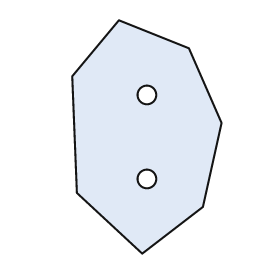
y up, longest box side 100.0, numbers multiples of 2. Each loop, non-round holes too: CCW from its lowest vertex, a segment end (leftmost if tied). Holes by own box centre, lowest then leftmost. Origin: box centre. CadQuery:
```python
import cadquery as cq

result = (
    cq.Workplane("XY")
    .moveTo(-2.0, -50.0)
    .lineTo(24.0, -30.0)
    .lineTo(32.0, 6.0)
    .lineTo(18.0, 38.0)
    .lineTo(-12.0, 50.0)
    .lineTo(-32.0, 26.0)
    .lineTo(-30.0, -24.0)
    .close()
    .moveTo(0.0, -18.0)
    .circle(4.0)
    .moveTo(0.0, 18.0)
    .circle(4.0)
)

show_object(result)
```